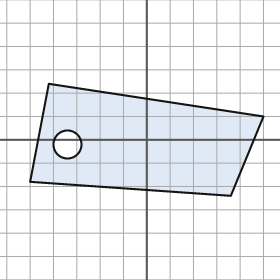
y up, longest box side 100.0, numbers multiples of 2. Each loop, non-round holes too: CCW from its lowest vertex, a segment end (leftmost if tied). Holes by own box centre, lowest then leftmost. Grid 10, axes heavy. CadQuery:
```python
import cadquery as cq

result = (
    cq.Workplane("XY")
    .moveTo(36.0, -24.0)
    .lineTo(50.0, 10.0)
    .lineTo(-42.0, 24.0)
    .lineTo(-50.0, -18.0)
    .close()
    .moveTo(-34.0, -2.0)
    .circle(6.0)
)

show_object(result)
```